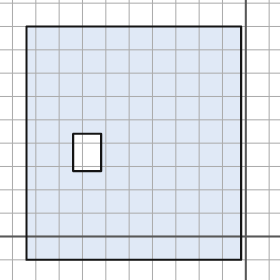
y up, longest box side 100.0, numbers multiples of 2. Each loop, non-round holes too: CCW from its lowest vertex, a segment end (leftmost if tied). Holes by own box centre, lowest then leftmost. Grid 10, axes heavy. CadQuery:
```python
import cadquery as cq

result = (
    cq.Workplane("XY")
    .moveTo(-94.0, -10.0)
    .lineTo(-2.0, -10.0)
    .lineTo(-2.0, 90.0)
    .lineTo(-94.0, 90.0)
    .close()
    .moveTo(-74.0, 28.0)
    .lineTo(-62.0, 28.0)
    .lineTo(-62.0, 44.0)
    .lineTo(-74.0, 44.0)
    .close()
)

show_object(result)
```